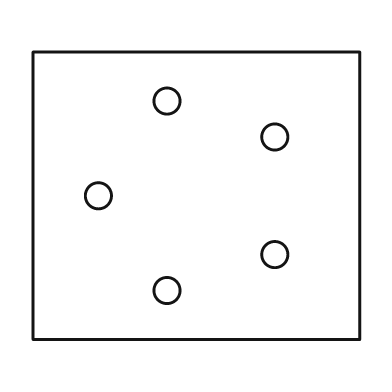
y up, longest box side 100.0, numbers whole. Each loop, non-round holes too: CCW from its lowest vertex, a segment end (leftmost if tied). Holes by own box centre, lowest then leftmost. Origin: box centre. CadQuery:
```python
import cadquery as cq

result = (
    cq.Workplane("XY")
    .moveTo(-50.0, -44.0)
    .lineTo(50.0, -44.0)
    .lineTo(50.0, 44.0)
    .lineTo(-50.0, 44.0)
    .close()
    .moveTo(-9.0, -29.0)
    .circle(4.0)
    .moveTo(24.0, -18.0)
    .circle(4.0)
    .moveTo(-30.0, 0.0)
    .circle(4.0)
    .moveTo(24.0, 18.0)
    .circle(4.0)
    .moveTo(-9.0, 29.0)
    .circle(4.0)
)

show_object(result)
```